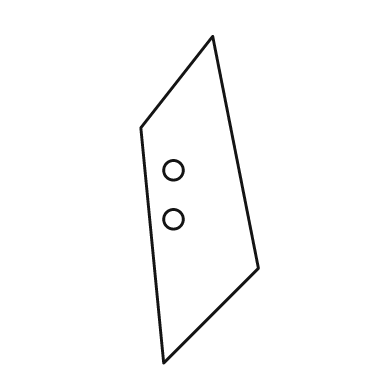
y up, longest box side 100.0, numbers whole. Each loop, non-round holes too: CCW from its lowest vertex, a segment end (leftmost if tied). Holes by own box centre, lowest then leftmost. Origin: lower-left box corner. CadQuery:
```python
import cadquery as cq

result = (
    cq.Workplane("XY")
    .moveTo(7.0, 0.0)
    .lineTo(36.0, 29.0)
    .lineTo(22.0, 100.0)
    .lineTo(0.0, 72.0)
    .close()
    .moveTo(10.0, 44.0)
    .circle(3.0)
    .moveTo(10.0, 59.0)
    .circle(3.0)
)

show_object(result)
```